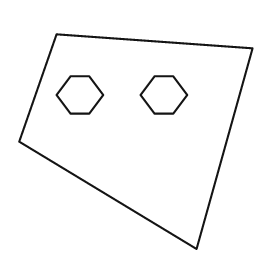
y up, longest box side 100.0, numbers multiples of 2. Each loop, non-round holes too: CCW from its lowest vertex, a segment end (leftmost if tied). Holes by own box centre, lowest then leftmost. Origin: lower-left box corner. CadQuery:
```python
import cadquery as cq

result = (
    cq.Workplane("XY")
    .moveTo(76.0, 0.0)
    .lineTo(100.0, 86.0)
    .lineTo(16.0, 92.0)
    .lineTo(0.0, 46.0)
    .close()
    .moveTo(22.0, 58.0)
    .lineTo(30.0, 58.0)
    .lineTo(36.0, 66.0)
    .lineTo(30.0, 74.0)
    .lineTo(22.0, 74.0)
    .lineTo(16.0, 66.0)
    .close()
    .moveTo(58.0, 58.0)
    .lineTo(66.0, 58.0)
    .lineTo(72.0, 66.0)
    .lineTo(66.0, 74.0)
    .lineTo(58.0, 74.0)
    .lineTo(52.0, 66.0)
    .close()
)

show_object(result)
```